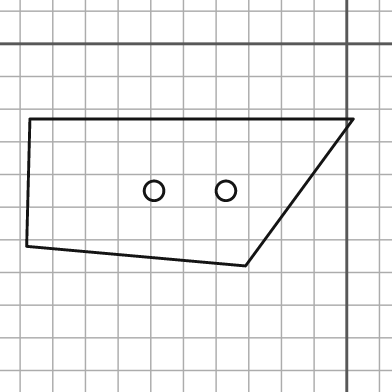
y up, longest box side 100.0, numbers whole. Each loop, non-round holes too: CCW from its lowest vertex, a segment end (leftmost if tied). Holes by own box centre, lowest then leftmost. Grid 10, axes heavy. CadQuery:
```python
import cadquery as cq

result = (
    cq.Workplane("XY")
    .moveTo(-31.0, -68.0)
    .lineTo(2.0, -23.0)
    .lineTo(-97.0, -23.0)
    .lineTo(-98.0, -62.0)
    .close()
    .moveTo(-59.0, -45.0)
    .circle(3.0)
    .moveTo(-37.0, -45.0)
    .circle(3.0)
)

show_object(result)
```